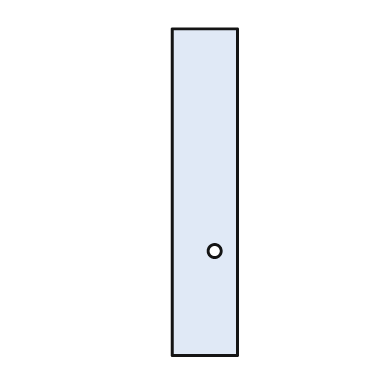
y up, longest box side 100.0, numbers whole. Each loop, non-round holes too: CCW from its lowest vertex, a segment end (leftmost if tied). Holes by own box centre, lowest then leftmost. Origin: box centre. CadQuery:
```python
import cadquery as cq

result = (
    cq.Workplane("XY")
    .moveTo(-10.0, -50.0)
    .lineTo(10.0, -50.0)
    .lineTo(10.0, 50.0)
    .lineTo(-10.0, 50.0)
    .close()
    .moveTo(3.0, -18.0)
    .circle(2.0)
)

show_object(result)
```